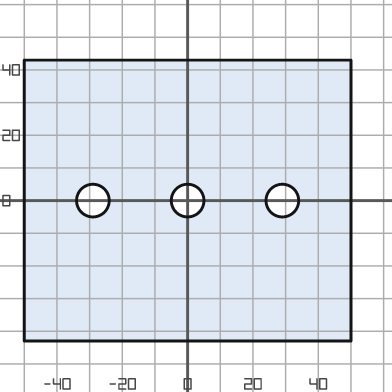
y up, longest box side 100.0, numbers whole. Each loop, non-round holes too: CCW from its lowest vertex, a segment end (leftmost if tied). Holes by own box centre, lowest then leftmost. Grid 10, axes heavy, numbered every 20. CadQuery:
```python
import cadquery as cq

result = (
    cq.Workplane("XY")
    .moveTo(-50.0, -43.0)
    .lineTo(50.0, -43.0)
    .lineTo(50.0, 43.0)
    .lineTo(-50.0, 43.0)
    .close()
    .moveTo(-29.0, 0.0)
    .circle(5.0)
    .moveTo(0.0, 0.0)
    .circle(5.0)
    .moveTo(29.0, 0.0)
    .circle(5.0)
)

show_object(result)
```